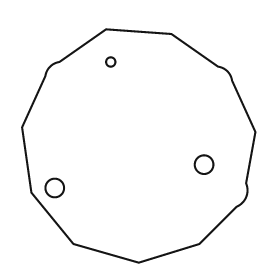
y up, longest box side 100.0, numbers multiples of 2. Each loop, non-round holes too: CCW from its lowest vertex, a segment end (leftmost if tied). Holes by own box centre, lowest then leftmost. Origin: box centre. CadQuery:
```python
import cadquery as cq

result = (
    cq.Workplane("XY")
    .moveTo(0.0, -50.0)
    .lineTo(26.0, -42.0)
    .lineTo(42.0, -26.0)
    .threePointArc((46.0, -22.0), (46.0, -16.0))
    .lineTo(50.0, 6.0)
    .lineTo(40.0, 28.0)
    .threePointArc((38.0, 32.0), (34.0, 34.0))
    .lineTo(14.0, 48.0)
    .lineTo(-14.0, 50.0)
    .lineTo(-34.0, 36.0)
    .threePointArc((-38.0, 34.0), (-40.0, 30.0))
    .lineTo(-50.0, 8.0)
    .lineTo(-46.0, -20.0)
    .lineTo(-28.0, -42.0)
    .close()
    .moveTo(-36.0, -18.0)
    .circle(4.0)
    .moveTo(28.0, -8.0)
    .circle(4.0)
    .moveTo(-12.0, 36.0)
    .circle(2.0)
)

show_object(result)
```